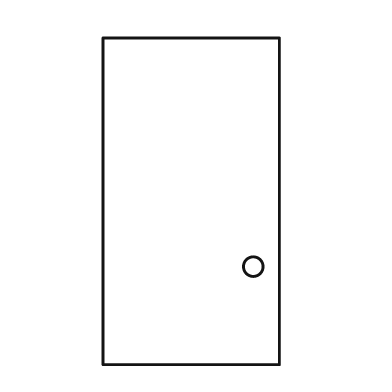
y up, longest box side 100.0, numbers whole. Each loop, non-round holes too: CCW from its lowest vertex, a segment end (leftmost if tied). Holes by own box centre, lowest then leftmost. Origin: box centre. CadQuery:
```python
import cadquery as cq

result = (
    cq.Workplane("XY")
    .moveTo(-27.0, -50.0)
    .lineTo(27.0, -50.0)
    .lineTo(27.0, 50.0)
    .lineTo(-27.0, 50.0)
    .close()
    .moveTo(19.0, -20.0)
    .circle(3.0)
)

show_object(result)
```